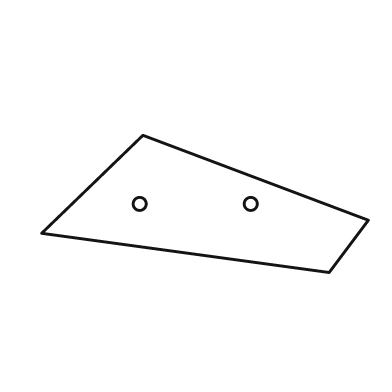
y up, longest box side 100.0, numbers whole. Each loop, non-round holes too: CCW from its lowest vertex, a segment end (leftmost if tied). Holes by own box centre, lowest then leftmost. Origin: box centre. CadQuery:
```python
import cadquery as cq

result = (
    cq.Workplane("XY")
    .moveTo(38.0, -21.0)
    .lineTo(50.0, -5.0)
    .lineTo(-19.0, 21.0)
    .lineTo(-50.0, -9.0)
    .close()
    .moveTo(-20.0, 0.0)
    .circle(2.0)
    .moveTo(14.0, 0.0)
    .circle(2.0)
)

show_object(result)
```